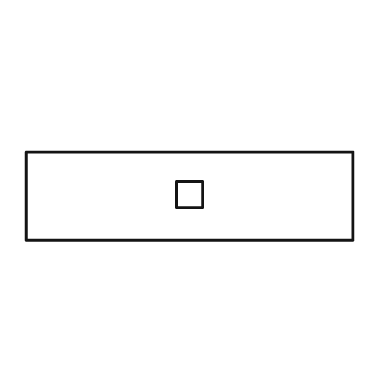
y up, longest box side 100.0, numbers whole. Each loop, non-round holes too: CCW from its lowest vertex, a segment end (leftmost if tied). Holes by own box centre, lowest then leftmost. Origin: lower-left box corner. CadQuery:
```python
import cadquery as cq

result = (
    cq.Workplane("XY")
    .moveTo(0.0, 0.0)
    .lineTo(100.0, 0.0)
    .lineTo(100.0, 27.0)
    .lineTo(0.0, 27.0)
    .close()
    .moveTo(46.0, 10.0)
    .lineTo(54.0, 10.0)
    .lineTo(54.0, 18.0)
    .lineTo(46.0, 18.0)
    .close()
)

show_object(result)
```